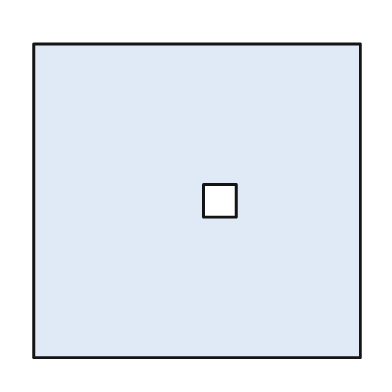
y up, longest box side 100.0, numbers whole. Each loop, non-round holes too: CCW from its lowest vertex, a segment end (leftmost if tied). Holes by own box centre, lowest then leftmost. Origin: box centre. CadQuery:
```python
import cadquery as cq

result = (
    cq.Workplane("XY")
    .moveTo(-50.0, -48.0)
    .lineTo(50.0, -48.0)
    .lineTo(50.0, 48.0)
    .lineTo(-50.0, 48.0)
    .close()
    .moveTo(2.0, -5.0)
    .lineTo(12.0, -5.0)
    .lineTo(12.0, 5.0)
    .lineTo(2.0, 5.0)
    .close()
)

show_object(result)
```